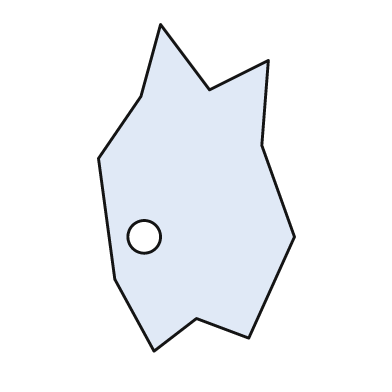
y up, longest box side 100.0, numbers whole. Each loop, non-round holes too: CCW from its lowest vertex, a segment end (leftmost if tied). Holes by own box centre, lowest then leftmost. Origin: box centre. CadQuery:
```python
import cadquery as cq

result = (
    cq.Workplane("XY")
    .moveTo(-13.0, -50.0)
    .lineTo(0.0, -40.0)
    .lineTo(16.0, -46.0)
    .lineTo(30.0, -15.0)
    .lineTo(20.0, 13.0)
    .lineTo(22.0, 39.0)
    .lineTo(4.0, 30.0)
    .lineTo(-11.0, 50.0)
    .lineTo(-17.0, 28.0)
    .lineTo(-30.0, 9.0)
    .lineTo(-25.0, -28.0)
    .close()
    .moveTo(-16.0, -15.0)
    .circle(5.0)
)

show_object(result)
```